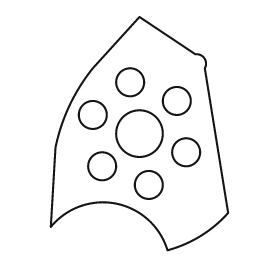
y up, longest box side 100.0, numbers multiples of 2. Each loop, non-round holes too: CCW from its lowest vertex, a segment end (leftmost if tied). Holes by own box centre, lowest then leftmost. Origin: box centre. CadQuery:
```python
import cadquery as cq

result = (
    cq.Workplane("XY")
    .moveTo(12.0, -50.0)
    .threePointArc((26.0, -44.0), (38.0, -34.0))
    .lineTo(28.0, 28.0)
    .threePointArc((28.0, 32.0), (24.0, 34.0))
    .lineTo(0.0, 50.0)
    .lineTo(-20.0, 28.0)
    .threePointArc((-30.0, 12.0), (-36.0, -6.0))
    .lineTo(-38.0, -40.0)
    .threePointArc((-10.0, -30.0), (12.0, -50.0))
    .close()
    .moveTo(4.0, -22.0)
    .circle(6.0)
    .moveTo(-16.0, -14.0)
    .circle(6.0)
    .moveTo(20.0, -8.0)
    .circle(6.0)
    .moveTo(0.0, 0.0)
    .circle(10.0)
    .moveTo(-20.0, 8.0)
    .circle(6.0)
    .moveTo(16.0, 14.0)
    .circle(6.0)
    .moveTo(-4.0, 22.0)
    .circle(6.0)
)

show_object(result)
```